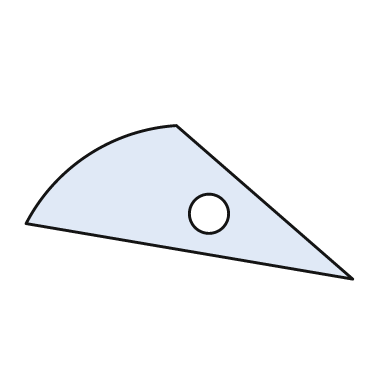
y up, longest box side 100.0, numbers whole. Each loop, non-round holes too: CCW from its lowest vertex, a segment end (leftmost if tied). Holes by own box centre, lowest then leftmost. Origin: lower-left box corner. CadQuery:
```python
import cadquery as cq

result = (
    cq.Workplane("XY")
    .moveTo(100.0, 0.0)
    .lineTo(46.0, 47.0)
    .threePointArc((19.0, 38.0), (0.0, 17.0))
    .close()
    .moveTo(56.0, 20.0)
    .circle(6.0)
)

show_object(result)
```